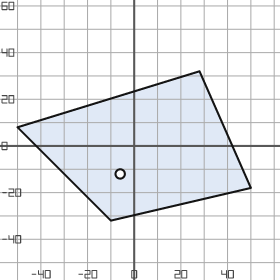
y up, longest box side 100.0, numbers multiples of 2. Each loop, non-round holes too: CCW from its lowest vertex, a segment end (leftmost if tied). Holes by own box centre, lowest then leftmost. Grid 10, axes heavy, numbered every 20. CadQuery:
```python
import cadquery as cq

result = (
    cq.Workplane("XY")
    .moveTo(-10.0, -32.0)
    .lineTo(50.0, -18.0)
    .lineTo(28.0, 32.0)
    .lineTo(-50.0, 8.0)
    .close()
    .moveTo(-6.0, -12.0)
    .circle(2.0)
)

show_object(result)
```